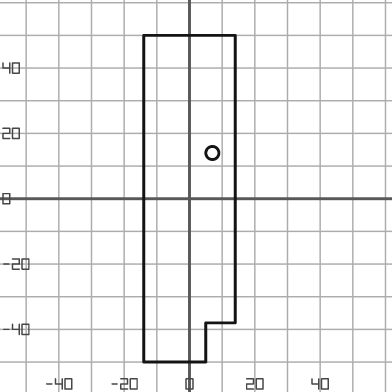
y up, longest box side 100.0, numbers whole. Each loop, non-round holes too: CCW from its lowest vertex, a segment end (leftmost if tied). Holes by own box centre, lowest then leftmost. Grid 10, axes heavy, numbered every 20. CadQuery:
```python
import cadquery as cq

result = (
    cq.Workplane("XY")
    .moveTo(-14.0, -50.0)
    .lineTo(5.0, -50.0)
    .lineTo(5.0, -38.0)
    .lineTo(14.0, -38.0)
    .lineTo(14.0, 50.0)
    .lineTo(-14.0, 50.0)
    .close()
    .moveTo(7.0, 14.0)
    .circle(2.0)
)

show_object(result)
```